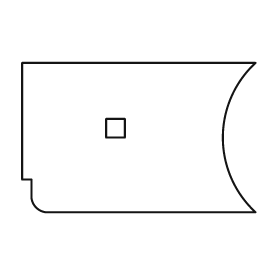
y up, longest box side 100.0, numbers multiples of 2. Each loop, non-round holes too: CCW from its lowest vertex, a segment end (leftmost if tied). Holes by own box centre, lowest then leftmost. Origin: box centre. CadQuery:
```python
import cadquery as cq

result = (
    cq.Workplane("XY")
    .moveTo(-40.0, -32.0)
    .lineTo(50.0, -32.0)
    .threePointArc((36.0, 0.0), (50.0, 32.0))
    .lineTo(-50.0, 32.0)
    .lineTo(-50.0, -18.0)
    .lineTo(-46.0, -18.0)
    .lineTo(-46.0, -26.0)
    .threePointArc((-44.0, -30.0), (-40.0, -32.0))
    .close()
    .moveTo(-14.0, 0.0)
    .lineTo(-6.0, 0.0)
    .lineTo(-6.0, 8.0)
    .lineTo(-14.0, 8.0)
    .close()
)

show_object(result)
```